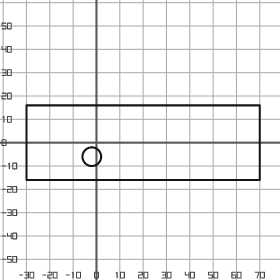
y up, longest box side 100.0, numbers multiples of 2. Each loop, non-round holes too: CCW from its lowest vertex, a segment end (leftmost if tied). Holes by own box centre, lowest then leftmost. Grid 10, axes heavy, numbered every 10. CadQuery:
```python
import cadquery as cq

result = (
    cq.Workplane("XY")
    .moveTo(-30.0, -16.0)
    .lineTo(70.0, -16.0)
    .lineTo(70.0, 16.0)
    .lineTo(-30.0, 16.0)
    .close()
    .moveTo(-2.0, -6.0)
    .circle(4.0)
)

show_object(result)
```